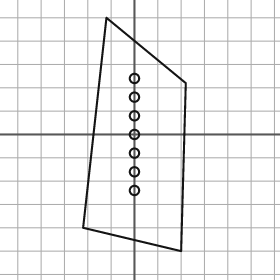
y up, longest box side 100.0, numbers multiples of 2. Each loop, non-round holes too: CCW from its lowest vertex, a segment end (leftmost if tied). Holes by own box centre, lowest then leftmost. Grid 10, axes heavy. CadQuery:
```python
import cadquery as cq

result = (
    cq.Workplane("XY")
    .moveTo(20.0, -50.0)
    .lineTo(22.0, 22.0)
    .lineTo(-12.0, 50.0)
    .lineTo(-22.0, -40.0)
    .close()
    .moveTo(0.0, -24.0)
    .circle(2.0)
    .moveTo(0.0, -16.0)
    .circle(2.0)
    .moveTo(0.0, -8.0)
    .circle(2.0)
    .moveTo(0.0, 0.0)
    .circle(2.0)
    .moveTo(0.0, 8.0)
    .circle(2.0)
    .moveTo(0.0, 16.0)
    .circle(2.0)
    .moveTo(0.0, 24.0)
    .circle(2.0)
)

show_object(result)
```